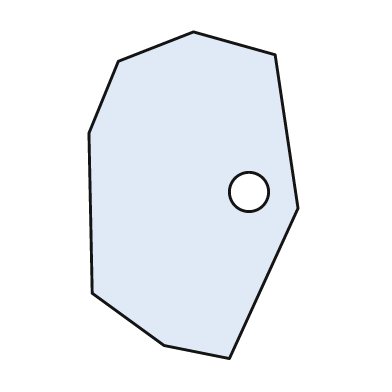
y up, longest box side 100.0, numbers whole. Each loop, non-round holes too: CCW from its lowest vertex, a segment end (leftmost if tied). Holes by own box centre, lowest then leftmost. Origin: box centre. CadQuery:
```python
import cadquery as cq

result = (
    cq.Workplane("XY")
    .moveTo(11.0, -50.0)
    .lineTo(32.0, -4.0)
    .lineTo(25.0, 43.0)
    .lineTo(0.0, 50.0)
    .lineTo(-23.0, 41.0)
    .lineTo(-32.0, 19.0)
    .lineTo(-31.0, -30.0)
    .lineTo(-9.0, -46.0)
    .close()
    .moveTo(17.0, 1.0)
    .circle(6.0)
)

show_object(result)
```